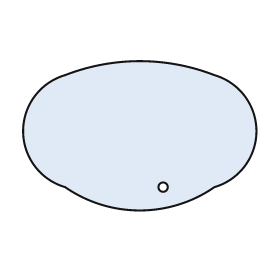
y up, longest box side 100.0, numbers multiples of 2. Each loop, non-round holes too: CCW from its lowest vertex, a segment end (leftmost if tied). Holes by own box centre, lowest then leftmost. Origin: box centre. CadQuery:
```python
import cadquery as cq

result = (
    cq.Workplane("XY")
    .moveTo(-32.0, -22.0)
    .threePointArc((0.0, -32.0), (32.0, -22.0))
    .threePointArc((50.0, 2.0), (32.0, 26.0))
    .threePointArc((0.0, 32.0), (-32.0, 26.0))
    .threePointArc((-50.0, 2.0), (-32.0, -22.0))
    .close()
    .moveTo(10.0, -22.0)
    .circle(2.0)
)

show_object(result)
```